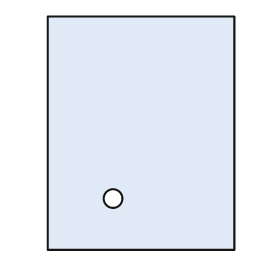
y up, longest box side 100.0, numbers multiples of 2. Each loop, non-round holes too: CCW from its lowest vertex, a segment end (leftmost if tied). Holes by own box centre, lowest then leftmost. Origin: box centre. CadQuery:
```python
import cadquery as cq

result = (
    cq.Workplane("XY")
    .moveTo(-40.0, -50.0)
    .lineTo(40.0, -50.0)
    .lineTo(40.0, 50.0)
    .lineTo(-40.0, 50.0)
    .close()
    .moveTo(-12.0, -28.0)
    .circle(4.0)
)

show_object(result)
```